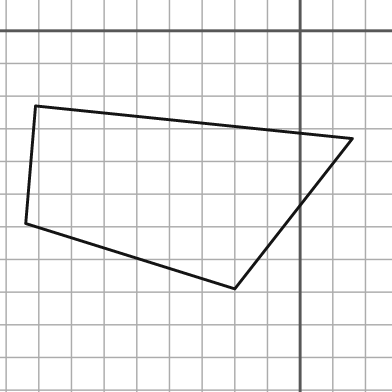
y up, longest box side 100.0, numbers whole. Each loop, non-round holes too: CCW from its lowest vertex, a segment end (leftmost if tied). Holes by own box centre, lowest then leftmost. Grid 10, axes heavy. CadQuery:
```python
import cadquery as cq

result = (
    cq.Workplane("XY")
    .moveTo(-20.0, -79.0)
    .lineTo(16.0, -33.0)
    .lineTo(-81.0, -23.0)
    .lineTo(-84.0, -59.0)
    .close()
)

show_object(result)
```